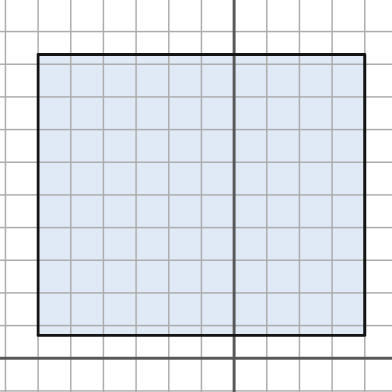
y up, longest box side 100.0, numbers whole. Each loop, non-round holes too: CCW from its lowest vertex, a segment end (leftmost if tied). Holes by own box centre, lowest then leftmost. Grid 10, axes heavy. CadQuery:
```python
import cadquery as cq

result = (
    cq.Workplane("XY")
    .moveTo(-60.0, 7.0)
    .lineTo(40.0, 7.0)
    .lineTo(40.0, 93.0)
    .lineTo(-60.0, 93.0)
    .close()
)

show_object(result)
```